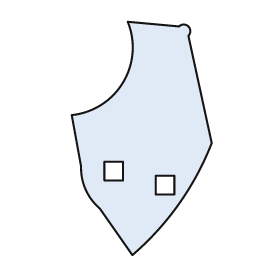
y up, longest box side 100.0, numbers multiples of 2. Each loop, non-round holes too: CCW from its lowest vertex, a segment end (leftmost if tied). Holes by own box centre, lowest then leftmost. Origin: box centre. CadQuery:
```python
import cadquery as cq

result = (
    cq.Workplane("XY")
    .moveTo(-4.0, -50.0)
    .threePointArc((16.0, -28.0), (30.0, -2.0))
    .lineTo(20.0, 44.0)
    .threePointArc((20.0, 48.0), (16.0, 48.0))
    .lineTo(-6.0, 50.0)
    .threePointArc((-8.0, 24.0), (-30.0, 10.0))
    .lineTo(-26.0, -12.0)
    .threePointArc((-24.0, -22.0), (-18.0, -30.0))
    .close()
    .moveTo(6.0, -24.0)
    .lineTo(14.0, -24.0)
    .lineTo(14.0, -16.0)
    .lineTo(6.0, -16.0)
    .close()
    .moveTo(-16.0, -18.0)
    .lineTo(-8.0, -18.0)
    .lineTo(-8.0, -10.0)
    .lineTo(-16.0, -10.0)
    .close()
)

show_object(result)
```